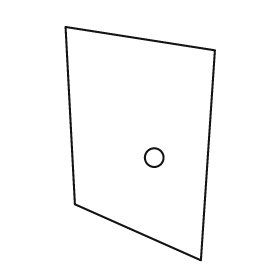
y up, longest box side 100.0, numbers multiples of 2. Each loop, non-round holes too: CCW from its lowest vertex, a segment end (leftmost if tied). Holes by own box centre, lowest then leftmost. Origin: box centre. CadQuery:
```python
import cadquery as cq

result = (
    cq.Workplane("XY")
    .moveTo(26.0, -50.0)
    .lineTo(32.0, 40.0)
    .lineTo(-32.0, 50.0)
    .lineTo(-28.0, -26.0)
    .close()
    .moveTo(6.0, -6.0)
    .circle(4.0)
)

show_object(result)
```